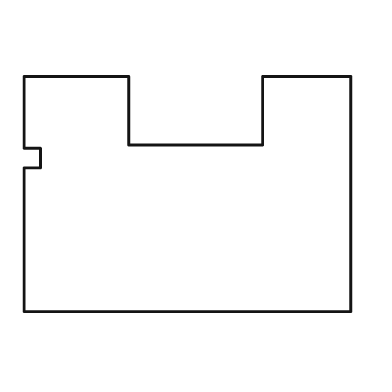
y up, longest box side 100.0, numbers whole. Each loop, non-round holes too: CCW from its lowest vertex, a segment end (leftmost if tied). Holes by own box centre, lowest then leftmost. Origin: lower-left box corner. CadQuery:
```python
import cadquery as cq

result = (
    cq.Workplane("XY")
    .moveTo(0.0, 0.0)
    .lineTo(100.0, 0.0)
    .lineTo(100.0, 72.0)
    .lineTo(73.0, 72.0)
    .lineTo(73.0, 51.0)
    .lineTo(32.0, 51.0)
    .lineTo(32.0, 72.0)
    .lineTo(0.0, 72.0)
    .lineTo(0.0, 50.0)
    .lineTo(5.0, 50.0)
    .lineTo(5.0, 44.0)
    .lineTo(0.0, 44.0)
    .close()
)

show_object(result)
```